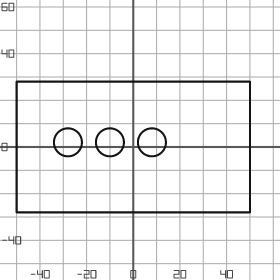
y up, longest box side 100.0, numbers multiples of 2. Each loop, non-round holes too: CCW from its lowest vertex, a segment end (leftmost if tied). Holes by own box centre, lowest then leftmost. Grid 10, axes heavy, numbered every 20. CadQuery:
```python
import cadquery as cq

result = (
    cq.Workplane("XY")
    .moveTo(-50.0, -28.0)
    .lineTo(50.0, -28.0)
    .lineTo(50.0, 28.0)
    .lineTo(-50.0, 28.0)
    .close()
    .moveTo(-28.0, 2.0)
    .circle(6.0)
    .moveTo(-10.0, 2.0)
    .circle(6.0)
    .moveTo(8.0, 2.0)
    .circle(6.0)
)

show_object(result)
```